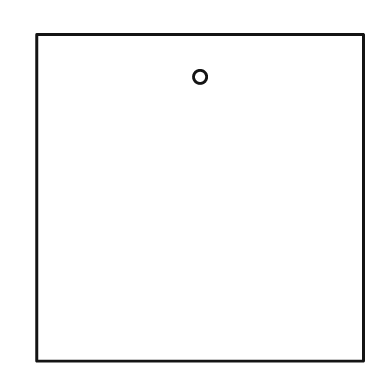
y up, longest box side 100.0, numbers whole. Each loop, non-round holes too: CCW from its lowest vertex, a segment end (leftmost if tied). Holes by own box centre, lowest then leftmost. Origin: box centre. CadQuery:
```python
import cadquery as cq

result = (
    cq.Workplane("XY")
    .moveTo(-50.0, -50.0)
    .lineTo(50.0, -50.0)
    .lineTo(50.0, 50.0)
    .lineTo(-50.0, 50.0)
    .close()
    .moveTo(0.0, 37.0)
    .circle(2.0)
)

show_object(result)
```